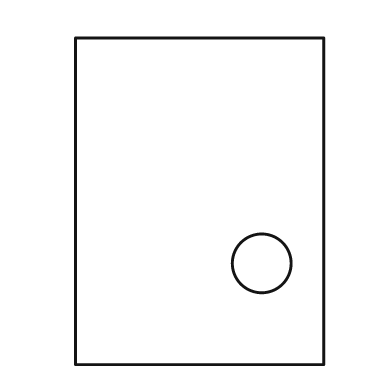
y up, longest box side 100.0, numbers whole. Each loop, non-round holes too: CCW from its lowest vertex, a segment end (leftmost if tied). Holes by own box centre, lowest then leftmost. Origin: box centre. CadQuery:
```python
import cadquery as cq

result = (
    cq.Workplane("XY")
    .moveTo(-38.0, -50.0)
    .lineTo(38.0, -50.0)
    .lineTo(38.0, 50.0)
    .lineTo(-38.0, 50.0)
    .close()
    .moveTo(19.0, -19.0)
    .circle(9.0)
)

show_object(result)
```